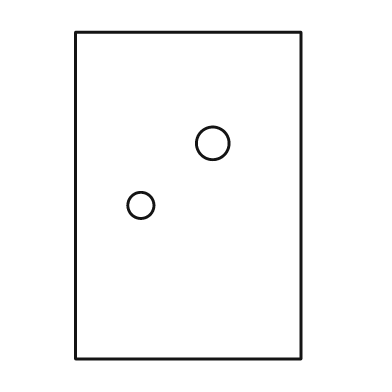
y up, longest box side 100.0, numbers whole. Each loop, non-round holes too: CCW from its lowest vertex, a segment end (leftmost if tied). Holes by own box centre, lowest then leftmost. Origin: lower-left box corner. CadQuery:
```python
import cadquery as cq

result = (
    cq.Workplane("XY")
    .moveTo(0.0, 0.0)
    .lineTo(69.0, 0.0)
    .lineTo(69.0, 100.0)
    .lineTo(0.0, 100.0)
    .close()
    .moveTo(20.0, 47.0)
    .circle(4.0)
    .moveTo(42.0, 66.0)
    .circle(5.0)
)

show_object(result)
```